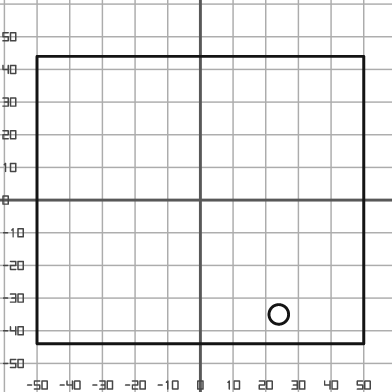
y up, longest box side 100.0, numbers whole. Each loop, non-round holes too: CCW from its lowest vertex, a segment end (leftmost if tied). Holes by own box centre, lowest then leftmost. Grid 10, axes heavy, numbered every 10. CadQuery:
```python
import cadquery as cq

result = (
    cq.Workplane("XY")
    .moveTo(-50.0, -44.0)
    .lineTo(50.0, -44.0)
    .lineTo(50.0, 44.0)
    .lineTo(-50.0, 44.0)
    .close()
    .moveTo(24.0, -35.0)
    .circle(3.0)
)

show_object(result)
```